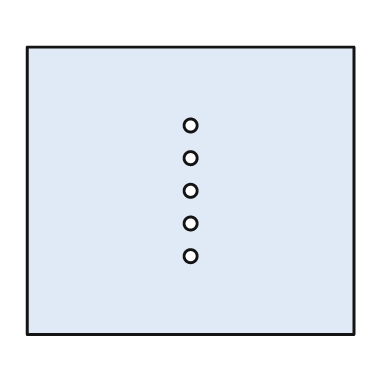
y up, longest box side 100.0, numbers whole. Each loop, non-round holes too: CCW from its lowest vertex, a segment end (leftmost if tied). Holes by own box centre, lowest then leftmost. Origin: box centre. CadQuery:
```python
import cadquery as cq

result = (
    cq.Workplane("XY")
    .moveTo(-50.0, -44.0)
    .lineTo(50.0, -44.0)
    .lineTo(50.0, 44.0)
    .lineTo(-50.0, 44.0)
    .close()
    .moveTo(0.0, -20.0)
    .circle(2.0)
    .moveTo(0.0, -10.0)
    .circle(2.0)
    .moveTo(0.0, 0.0)
    .circle(2.0)
    .moveTo(0.0, 10.0)
    .circle(2.0)
    .moveTo(0.0, 20.0)
    .circle(2.0)
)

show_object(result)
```